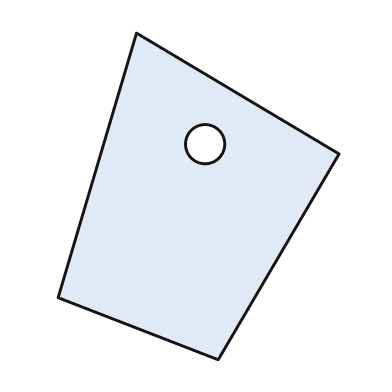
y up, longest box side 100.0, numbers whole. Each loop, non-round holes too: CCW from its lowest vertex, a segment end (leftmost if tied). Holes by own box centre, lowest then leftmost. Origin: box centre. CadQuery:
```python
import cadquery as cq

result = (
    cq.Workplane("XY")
    .moveTo(6.0, -50.0)
    .lineTo(43.0, 13.0)
    .lineTo(-19.0, 50.0)
    .lineTo(-43.0, -31.0)
    .close()
    .moveTo(2.0, 16.0)
    .circle(6.0)
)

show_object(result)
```